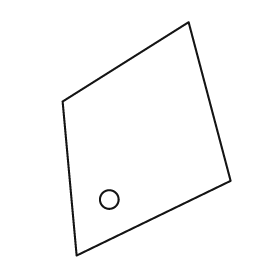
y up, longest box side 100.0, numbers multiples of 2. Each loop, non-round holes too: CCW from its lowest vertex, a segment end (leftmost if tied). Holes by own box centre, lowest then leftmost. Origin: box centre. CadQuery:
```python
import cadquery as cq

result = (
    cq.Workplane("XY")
    .moveTo(-30.0, -50.0)
    .lineTo(36.0, -18.0)
    .lineTo(18.0, 50.0)
    .lineTo(-36.0, 16.0)
    .close()
    .moveTo(-16.0, -26.0)
    .circle(4.0)
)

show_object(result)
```